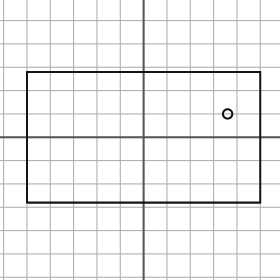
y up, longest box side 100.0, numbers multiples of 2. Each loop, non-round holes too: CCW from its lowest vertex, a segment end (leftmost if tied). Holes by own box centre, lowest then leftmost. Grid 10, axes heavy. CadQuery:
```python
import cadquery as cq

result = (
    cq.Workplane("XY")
    .moveTo(-50.0, -28.0)
    .lineTo(50.0, -28.0)
    .lineTo(50.0, 28.0)
    .lineTo(-50.0, 28.0)
    .close()
    .moveTo(36.0, 10.0)
    .circle(2.0)
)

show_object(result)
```